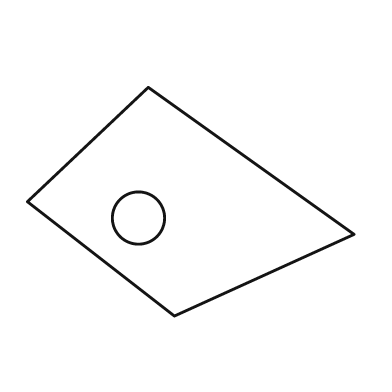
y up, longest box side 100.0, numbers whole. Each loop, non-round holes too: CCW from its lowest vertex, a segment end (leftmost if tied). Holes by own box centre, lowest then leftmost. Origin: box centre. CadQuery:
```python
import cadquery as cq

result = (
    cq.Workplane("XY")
    .moveTo(-5.0, -35.0)
    .lineTo(50.0, -10.0)
    .lineTo(-13.0, 35.0)
    .lineTo(-50.0, 0.0)
    .close()
    .moveTo(-16.0, -5.0)
    .circle(8.0)
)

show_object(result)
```